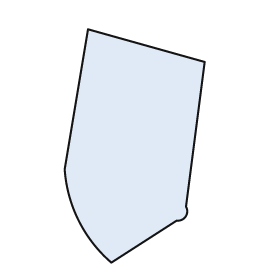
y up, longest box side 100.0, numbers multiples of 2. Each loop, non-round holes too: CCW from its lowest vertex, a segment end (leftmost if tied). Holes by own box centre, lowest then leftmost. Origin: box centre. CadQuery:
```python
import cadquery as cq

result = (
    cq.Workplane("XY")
    .moveTo(-10.0, -50.0)
    .lineTo(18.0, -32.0)
    .threePointArc((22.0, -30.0), (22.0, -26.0))
    .lineTo(30.0, 36.0)
    .lineTo(-20.0, 50.0)
    .lineTo(-30.0, -10.0)
    .threePointArc((-24.0, -32.0), (-10.0, -50.0))
    .close()
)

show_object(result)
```